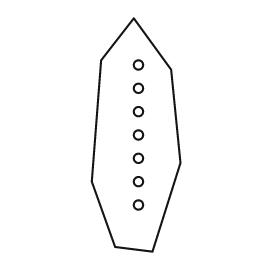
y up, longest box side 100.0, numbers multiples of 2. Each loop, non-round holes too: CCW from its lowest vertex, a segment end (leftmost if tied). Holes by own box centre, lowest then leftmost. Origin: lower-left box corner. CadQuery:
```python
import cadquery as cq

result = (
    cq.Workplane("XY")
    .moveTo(26.0, 0.0)
    .lineTo(38.0, 38.0)
    .lineTo(34.0, 78.0)
    .lineTo(18.0, 100.0)
    .lineTo(4.0, 82.0)
    .lineTo(0.0, 30.0)
    .lineTo(10.0, 2.0)
    .close()
    .moveTo(20.0, 20.0)
    .circle(2.0)
    .moveTo(20.0, 30.0)
    .circle(2.0)
    .moveTo(20.0, 40.0)
    .circle(2.0)
    .moveTo(20.0, 50.0)
    .circle(2.0)
    .moveTo(20.0, 60.0)
    .circle(2.0)
    .moveTo(20.0, 70.0)
    .circle(2.0)
    .moveTo(20.0, 80.0)
    .circle(2.0)
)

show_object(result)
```